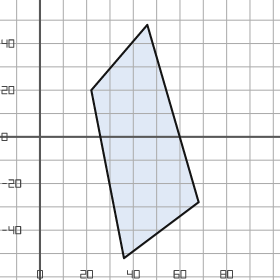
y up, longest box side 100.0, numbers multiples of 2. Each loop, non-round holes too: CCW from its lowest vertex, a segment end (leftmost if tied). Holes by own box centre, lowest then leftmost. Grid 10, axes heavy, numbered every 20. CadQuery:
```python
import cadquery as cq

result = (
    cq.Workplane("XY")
    .moveTo(36.0, -52.0)
    .lineTo(68.0, -28.0)
    .lineTo(46.0, 48.0)
    .lineTo(22.0, 20.0)
    .close()
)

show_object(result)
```